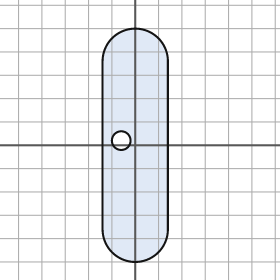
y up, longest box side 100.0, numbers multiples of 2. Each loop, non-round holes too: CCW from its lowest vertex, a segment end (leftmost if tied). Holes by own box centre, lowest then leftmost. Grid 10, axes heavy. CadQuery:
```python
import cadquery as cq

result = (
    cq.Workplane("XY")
    .moveTo(-14.0, -36.0)
    .threePointArc((0.0, -50.0), (14.0, -36.0))
    .lineTo(14.0, 36.0)
    .threePointArc((0.0, 50.0), (-14.0, 36.0))
    .close()
    .moveTo(-6.0, 2.0)
    .circle(4.0)
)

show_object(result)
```